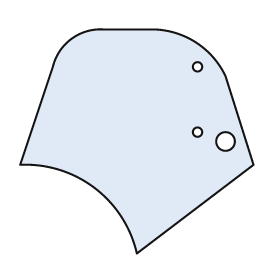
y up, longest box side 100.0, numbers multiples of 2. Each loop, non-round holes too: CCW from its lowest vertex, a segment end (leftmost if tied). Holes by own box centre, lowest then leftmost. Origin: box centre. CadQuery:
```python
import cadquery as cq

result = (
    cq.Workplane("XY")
    .moveTo(0.0, -48.0)
    .lineTo(50.0, -10.0)
    .lineTo(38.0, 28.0)
    .threePointArc((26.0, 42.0), (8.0, 48.0))
    .lineTo(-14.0, 48.0)
    .threePointArc((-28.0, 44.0), (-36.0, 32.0))
    .lineTo(-50.0, -10.0)
    .threePointArc((-18.0, -20.0), (0.0, -48.0))
    .close()
    .moveTo(38.0, 0.0)
    .circle(4.0)
    .moveTo(26.0, 4.0)
    .circle(2.0)
    .moveTo(26.0, 32.0)
    .circle(2.0)
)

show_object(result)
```